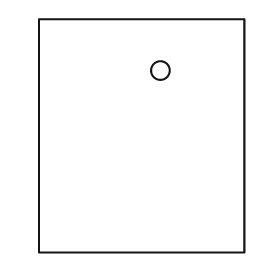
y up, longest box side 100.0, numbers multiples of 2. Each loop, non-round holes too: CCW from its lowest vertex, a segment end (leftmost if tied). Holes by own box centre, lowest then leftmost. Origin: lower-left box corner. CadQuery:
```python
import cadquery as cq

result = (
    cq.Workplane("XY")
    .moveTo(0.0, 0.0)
    .lineTo(88.0, 0.0)
    .lineTo(88.0, 100.0)
    .lineTo(0.0, 100.0)
    .close()
    .moveTo(52.0, 78.0)
    .circle(4.0)
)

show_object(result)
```